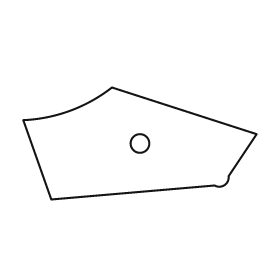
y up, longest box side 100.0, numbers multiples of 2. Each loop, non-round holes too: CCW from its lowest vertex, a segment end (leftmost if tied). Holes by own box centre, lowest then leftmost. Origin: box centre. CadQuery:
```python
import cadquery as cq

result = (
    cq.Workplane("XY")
    .moveTo(-38.0, -24.0)
    .lineTo(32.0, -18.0)
    .threePointArc((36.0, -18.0), (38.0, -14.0))
    .lineTo(50.0, 4.0)
    .lineTo(-12.0, 24.0)
    .threePointArc((-30.0, 14.0), (-50.0, 10.0))
    .close()
    .moveTo(0.0, 0.0)
    .circle(4.0)
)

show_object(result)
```